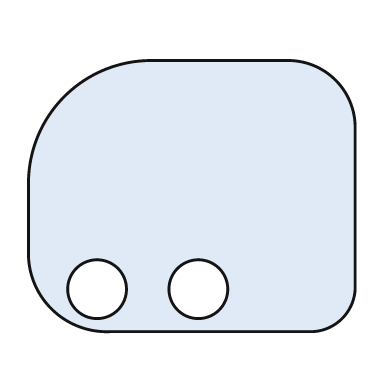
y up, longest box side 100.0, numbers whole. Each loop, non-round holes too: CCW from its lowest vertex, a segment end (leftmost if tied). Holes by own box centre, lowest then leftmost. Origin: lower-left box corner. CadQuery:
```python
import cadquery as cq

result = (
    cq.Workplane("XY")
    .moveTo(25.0, 0.0)
    .lineTo(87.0, 0.0)
    .threePointArc((96.0, 4.0), (100.0, 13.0))
    .lineTo(100.0, 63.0)
    .threePointArc((94.0, 77.0), (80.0, 83.0))
    .lineTo(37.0, 83.0)
    .threePointArc((11.0, 72.0), (0.0, 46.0))
    .lineTo(0.0, 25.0)
    .threePointArc((7.0, 7.0), (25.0, 0.0))
    .close()
    .moveTo(21.0, 13.0)
    .circle(9.0)
    .moveTo(52.0, 13.0)
    .circle(9.0)
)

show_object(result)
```